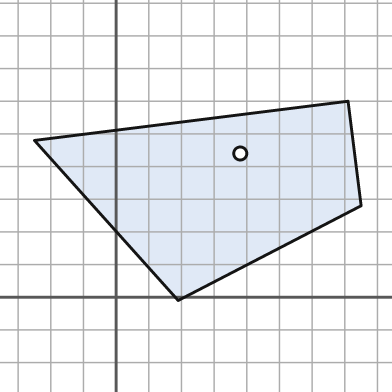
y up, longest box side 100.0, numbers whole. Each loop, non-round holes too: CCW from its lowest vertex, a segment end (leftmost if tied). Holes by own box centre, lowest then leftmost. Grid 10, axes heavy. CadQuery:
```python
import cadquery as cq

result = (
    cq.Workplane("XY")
    .moveTo(19.0, -1.0)
    .lineTo(75.0, 28.0)
    .lineTo(71.0, 60.0)
    .lineTo(-25.0, 48.0)
    .close()
    .moveTo(38.0, 44.0)
    .circle(2.0)
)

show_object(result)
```